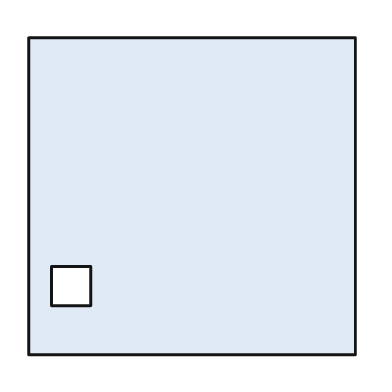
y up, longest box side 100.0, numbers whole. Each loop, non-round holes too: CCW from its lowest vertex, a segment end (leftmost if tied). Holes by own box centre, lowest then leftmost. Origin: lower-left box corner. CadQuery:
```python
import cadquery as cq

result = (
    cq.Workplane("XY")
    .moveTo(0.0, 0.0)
    .lineTo(100.0, 0.0)
    .lineTo(100.0, 97.0)
    .lineTo(0.0, 97.0)
    .close()
    .moveTo(7.0, 15.0)
    .lineTo(19.0, 15.0)
    .lineTo(19.0, 27.0)
    .lineTo(7.0, 27.0)
    .close()
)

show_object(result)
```